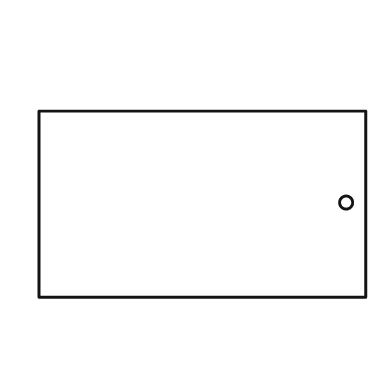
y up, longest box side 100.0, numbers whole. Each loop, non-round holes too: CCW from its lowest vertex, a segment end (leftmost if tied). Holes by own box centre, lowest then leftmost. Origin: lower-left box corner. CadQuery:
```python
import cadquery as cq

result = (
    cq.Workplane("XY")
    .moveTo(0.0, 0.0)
    .lineTo(100.0, 0.0)
    .lineTo(100.0, 57.0)
    .lineTo(0.0, 57.0)
    .close()
    .moveTo(94.0, 29.0)
    .circle(2.0)
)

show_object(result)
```